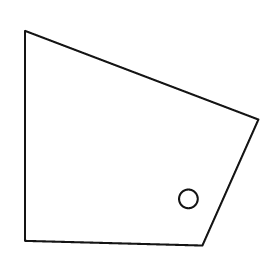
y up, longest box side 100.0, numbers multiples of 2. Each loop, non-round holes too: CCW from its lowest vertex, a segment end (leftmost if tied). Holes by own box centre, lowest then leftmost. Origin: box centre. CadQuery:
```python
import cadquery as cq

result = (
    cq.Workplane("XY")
    .moveTo(26.0, -46.0)
    .lineTo(50.0, 8.0)
    .lineTo(-50.0, 46.0)
    .lineTo(-50.0, -44.0)
    .close()
    .moveTo(20.0, -26.0)
    .circle(4.0)
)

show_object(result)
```